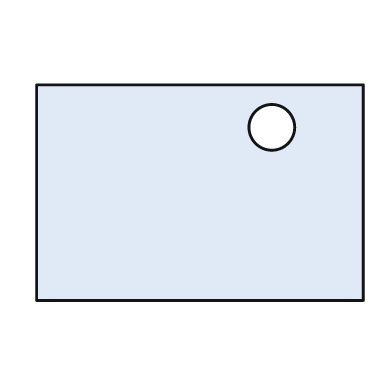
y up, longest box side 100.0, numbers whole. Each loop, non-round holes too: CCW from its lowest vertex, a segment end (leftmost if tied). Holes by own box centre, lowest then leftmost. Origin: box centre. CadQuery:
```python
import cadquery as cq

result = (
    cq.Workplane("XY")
    .moveTo(-50.0, -33.0)
    .lineTo(50.0, -33.0)
    .lineTo(50.0, 33.0)
    .lineTo(-50.0, 33.0)
    .close()
    .moveTo(22.0, 20.0)
    .circle(7.0)
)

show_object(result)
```